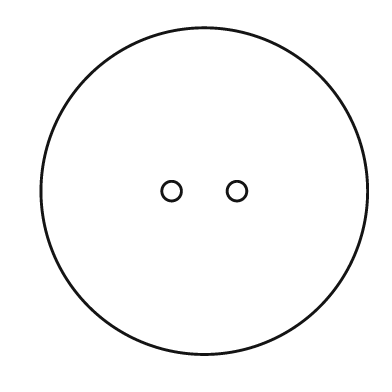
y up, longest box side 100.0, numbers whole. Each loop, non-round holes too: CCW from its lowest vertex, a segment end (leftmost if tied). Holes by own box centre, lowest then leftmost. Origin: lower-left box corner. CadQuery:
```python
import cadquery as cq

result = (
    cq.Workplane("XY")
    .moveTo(50.0, 50.0)
    .circle(50.0)
    .moveTo(40.0, 50.0)
    .circle(3.0)
    .moveTo(60.0, 50.0)
    .circle(3.0)
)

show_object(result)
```